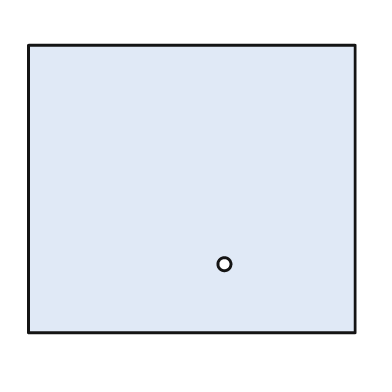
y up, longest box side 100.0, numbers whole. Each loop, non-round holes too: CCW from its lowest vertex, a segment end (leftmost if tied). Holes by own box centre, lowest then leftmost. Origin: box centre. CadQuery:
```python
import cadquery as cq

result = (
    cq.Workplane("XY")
    .moveTo(-50.0, -44.0)
    .lineTo(50.0, -44.0)
    .lineTo(50.0, 44.0)
    .lineTo(-50.0, 44.0)
    .close()
    .moveTo(10.0, -23.0)
    .circle(2.0)
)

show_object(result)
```